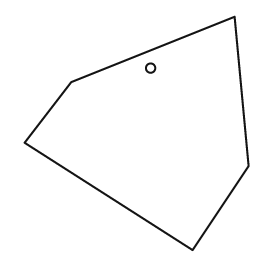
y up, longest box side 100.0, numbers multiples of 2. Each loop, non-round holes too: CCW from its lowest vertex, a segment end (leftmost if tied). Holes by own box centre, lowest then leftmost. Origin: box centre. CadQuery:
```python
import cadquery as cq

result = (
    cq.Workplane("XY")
    .moveTo(24.0, -50.0)
    .lineTo(48.0, -14.0)
    .lineTo(42.0, 50.0)
    .lineTo(-28.0, 22.0)
    .lineTo(-48.0, -4.0)
    .close()
    .moveTo(6.0, 28.0)
    .circle(2.0)
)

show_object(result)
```